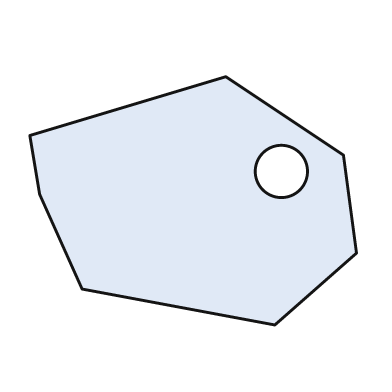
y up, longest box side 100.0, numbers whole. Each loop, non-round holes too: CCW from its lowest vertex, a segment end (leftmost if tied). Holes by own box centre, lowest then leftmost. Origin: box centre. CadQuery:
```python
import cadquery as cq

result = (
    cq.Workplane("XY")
    .moveTo(25.0, -38.0)
    .lineTo(50.0, -16.0)
    .lineTo(46.0, 14.0)
    .lineTo(10.0, 38.0)
    .lineTo(-50.0, 20.0)
    .lineTo(-47.0, 2.0)
    .lineTo(-34.0, -27.0)
    .close()
    .moveTo(27.0, 9.0)
    .circle(8.0)
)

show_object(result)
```